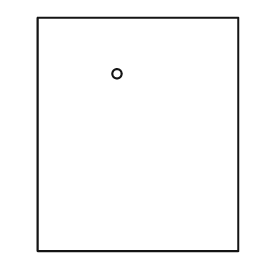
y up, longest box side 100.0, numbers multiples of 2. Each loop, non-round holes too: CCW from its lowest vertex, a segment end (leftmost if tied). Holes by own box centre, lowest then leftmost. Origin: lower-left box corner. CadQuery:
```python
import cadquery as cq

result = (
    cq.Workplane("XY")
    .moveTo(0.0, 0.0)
    .lineTo(86.0, 0.0)
    .lineTo(86.0, 100.0)
    .lineTo(0.0, 100.0)
    .close()
    .moveTo(34.0, 76.0)
    .circle(2.0)
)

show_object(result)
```